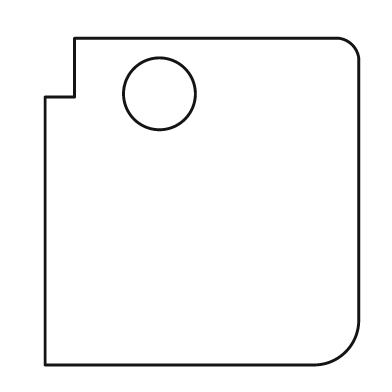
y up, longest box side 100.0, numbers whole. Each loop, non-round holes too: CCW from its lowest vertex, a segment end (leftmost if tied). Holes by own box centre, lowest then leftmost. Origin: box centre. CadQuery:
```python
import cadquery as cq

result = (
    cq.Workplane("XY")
    .moveTo(-48.0, -50.0)
    .lineTo(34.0, -50.0)
    .threePointArc((44.0, -46.0), (48.0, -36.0))
    .lineTo(48.0, 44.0)
    .threePointArc((46.0, 48.0), (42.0, 50.0))
    .lineTo(-39.0, 50.0)
    .lineTo(-39.0, 32.0)
    .lineTo(-48.0, 32.0)
    .close()
    .moveTo(-13.0, 33.0)
    .circle(11.0)
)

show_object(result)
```